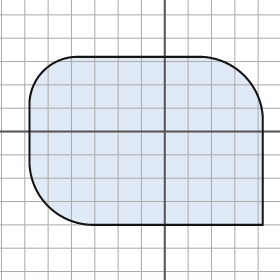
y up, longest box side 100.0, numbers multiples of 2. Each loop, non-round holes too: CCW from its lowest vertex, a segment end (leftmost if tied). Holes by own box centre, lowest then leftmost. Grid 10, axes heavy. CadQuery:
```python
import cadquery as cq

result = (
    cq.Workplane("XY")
    .moveTo(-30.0, -40.0)
    .lineTo(42.0, -40.0)
    .lineTo(42.0, 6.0)
    .threePointArc((34.0, 24.0), (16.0, 32.0))
    .lineTo(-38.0, 32.0)
    .threePointArc((-52.0, 26.0), (-58.0, 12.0))
    .lineTo(-58.0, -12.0)
    .threePointArc((-50.0, -32.0), (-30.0, -40.0))
    .close()
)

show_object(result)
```